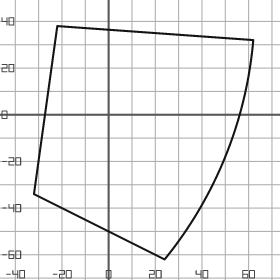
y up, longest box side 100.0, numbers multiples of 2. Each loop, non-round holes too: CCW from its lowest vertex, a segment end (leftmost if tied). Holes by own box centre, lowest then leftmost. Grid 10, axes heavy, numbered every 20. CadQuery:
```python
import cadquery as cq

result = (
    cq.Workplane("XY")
    .moveTo(24.0, -62.0)
    .threePointArc((50.0, -18.0), (62.0, 32.0))
    .lineTo(-22.0, 38.0)
    .lineTo(-32.0, -34.0)
    .close()
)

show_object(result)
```